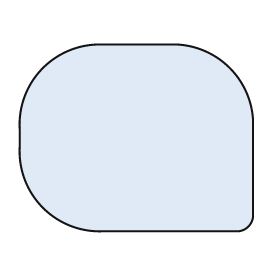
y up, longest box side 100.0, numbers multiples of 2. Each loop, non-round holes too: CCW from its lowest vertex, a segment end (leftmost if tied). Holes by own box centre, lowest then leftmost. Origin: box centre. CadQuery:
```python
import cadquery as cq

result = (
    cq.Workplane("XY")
    .moveTo(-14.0, -40.0)
    .lineTo(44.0, -40.0)
    .threePointArc((48.0, -38.0), (50.0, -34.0))
    .lineTo(50.0, 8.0)
    .threePointArc((40.0, 30.0), (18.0, 40.0))
    .lineTo(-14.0, 40.0)
    .threePointArc((-40.0, 30.0), (-50.0, 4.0))
    .lineTo(-50.0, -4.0)
    .threePointArc((-40.0, -30.0), (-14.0, -40.0))
    .close()
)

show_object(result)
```